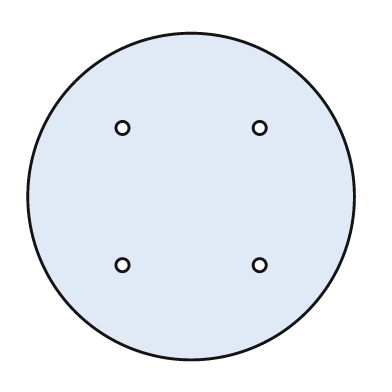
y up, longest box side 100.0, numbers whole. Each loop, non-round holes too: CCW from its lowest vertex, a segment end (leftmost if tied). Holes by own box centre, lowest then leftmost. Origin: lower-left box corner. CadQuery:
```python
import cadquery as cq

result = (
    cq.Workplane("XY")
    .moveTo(50.0, 50.0)
    .circle(50.0)
    .moveTo(29.0, 29.0)
    .circle(2.0)
    .moveTo(71.0, 29.0)
    .circle(2.0)
    .moveTo(29.0, 71.0)
    .circle(2.0)
    .moveTo(71.0, 71.0)
    .circle(2.0)
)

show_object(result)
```